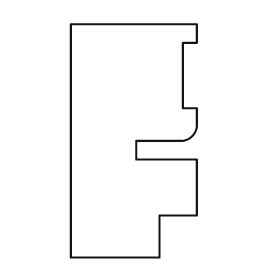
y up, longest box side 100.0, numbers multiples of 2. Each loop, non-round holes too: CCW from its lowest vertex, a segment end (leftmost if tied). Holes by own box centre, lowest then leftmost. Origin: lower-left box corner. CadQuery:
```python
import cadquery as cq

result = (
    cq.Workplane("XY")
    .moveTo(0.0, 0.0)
    .lineTo(38.0, 0.0)
    .lineTo(38.0, 18.0)
    .lineTo(54.0, 18.0)
    .lineTo(54.0, 42.0)
    .lineTo(28.0, 42.0)
    .lineTo(28.0, 50.0)
    .lineTo(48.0, 50.0)
    .threePointArc((52.0, 52.0), (54.0, 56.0))
    .lineTo(54.0, 64.0)
    .lineTo(48.0, 64.0)
    .lineTo(48.0, 92.0)
    .lineTo(54.0, 92.0)
    .lineTo(54.0, 100.0)
    .lineTo(0.0, 100.0)
    .close()
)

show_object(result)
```